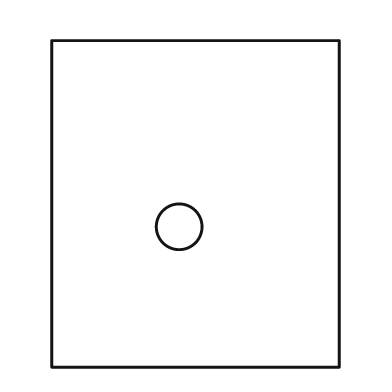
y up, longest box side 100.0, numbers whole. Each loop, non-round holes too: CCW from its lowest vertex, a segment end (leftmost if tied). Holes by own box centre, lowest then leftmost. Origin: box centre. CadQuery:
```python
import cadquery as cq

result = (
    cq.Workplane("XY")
    .moveTo(-44.0, -50.0)
    .lineTo(44.0, -50.0)
    .lineTo(44.0, 50.0)
    .lineTo(-44.0, 50.0)
    .close()
    .moveTo(-5.0, -7.0)
    .circle(7.0)
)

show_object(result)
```